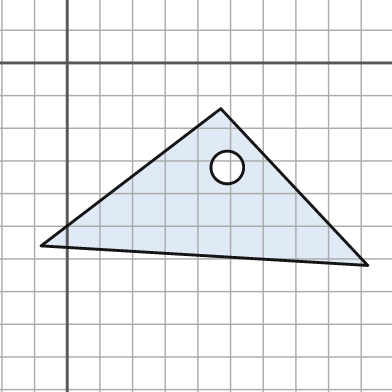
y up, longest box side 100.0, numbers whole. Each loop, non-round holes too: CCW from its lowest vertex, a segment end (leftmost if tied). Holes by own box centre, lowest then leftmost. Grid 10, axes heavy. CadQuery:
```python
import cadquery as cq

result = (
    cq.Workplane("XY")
    .moveTo(92.0, -62.0)
    .lineTo(47.0, -14.0)
    .lineTo(-8.0, -56.0)
    .close()
    .moveTo(49.0, -32.0)
    .circle(5.0)
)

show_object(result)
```